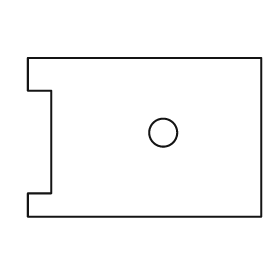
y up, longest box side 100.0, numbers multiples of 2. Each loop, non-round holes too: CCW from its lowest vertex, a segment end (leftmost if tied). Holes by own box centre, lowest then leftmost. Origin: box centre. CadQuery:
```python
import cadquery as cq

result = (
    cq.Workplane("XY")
    .moveTo(-50.0, -34.0)
    .lineTo(50.0, -34.0)
    .lineTo(50.0, 34.0)
    .lineTo(-50.0, 34.0)
    .lineTo(-50.0, 20.0)
    .lineTo(-40.0, 20.0)
    .lineTo(-40.0, -24.0)
    .lineTo(-50.0, -24.0)
    .close()
    .moveTo(8.0, 2.0)
    .circle(6.0)
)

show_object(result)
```